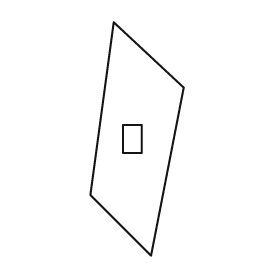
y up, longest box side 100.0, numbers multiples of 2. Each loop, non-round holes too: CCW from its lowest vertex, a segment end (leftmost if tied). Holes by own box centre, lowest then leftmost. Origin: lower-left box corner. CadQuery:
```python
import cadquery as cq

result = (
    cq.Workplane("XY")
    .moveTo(26.0, 0.0)
    .lineTo(40.0, 72.0)
    .lineTo(10.0, 100.0)
    .lineTo(0.0, 26.0)
    .close()
    .moveTo(14.0, 44.0)
    .lineTo(22.0, 44.0)
    .lineTo(22.0, 56.0)
    .lineTo(14.0, 56.0)
    .close()
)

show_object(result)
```